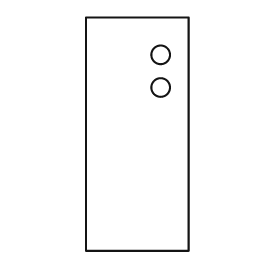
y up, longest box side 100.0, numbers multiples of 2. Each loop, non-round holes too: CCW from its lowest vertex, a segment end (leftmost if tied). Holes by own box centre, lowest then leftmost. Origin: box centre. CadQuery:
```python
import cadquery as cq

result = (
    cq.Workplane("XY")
    .moveTo(-22.0, -50.0)
    .lineTo(22.0, -50.0)
    .lineTo(22.0, 50.0)
    .lineTo(-22.0, 50.0)
    .close()
    .moveTo(10.0, 20.0)
    .circle(4.0)
    .moveTo(10.0, 34.0)
    .circle(4.0)
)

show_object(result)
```